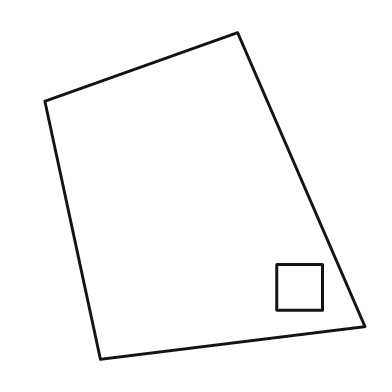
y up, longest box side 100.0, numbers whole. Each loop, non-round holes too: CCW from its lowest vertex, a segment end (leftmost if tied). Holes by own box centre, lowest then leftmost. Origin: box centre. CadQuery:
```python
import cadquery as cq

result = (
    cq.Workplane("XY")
    .moveTo(-32.0, -50.0)
    .lineTo(49.0, -40.0)
    .lineTo(10.0, 50.0)
    .lineTo(-49.0, 29.0)
    .close()
    .moveTo(22.0, -35.0)
    .lineTo(36.0, -35.0)
    .lineTo(36.0, -21.0)
    .lineTo(22.0, -21.0)
    .close()
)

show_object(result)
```